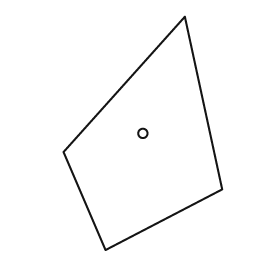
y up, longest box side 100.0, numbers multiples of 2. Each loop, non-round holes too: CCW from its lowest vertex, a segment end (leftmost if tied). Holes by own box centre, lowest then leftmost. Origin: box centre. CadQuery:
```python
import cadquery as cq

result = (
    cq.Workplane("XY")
    .moveTo(-16.0, -50.0)
    .lineTo(34.0, -24.0)
    .lineTo(18.0, 50.0)
    .lineTo(-34.0, -8.0)
    .close()
    .moveTo(0.0, 0.0)
    .circle(2.0)
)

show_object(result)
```